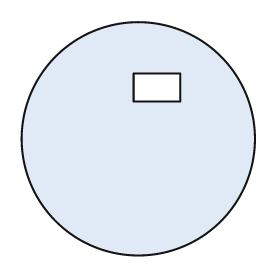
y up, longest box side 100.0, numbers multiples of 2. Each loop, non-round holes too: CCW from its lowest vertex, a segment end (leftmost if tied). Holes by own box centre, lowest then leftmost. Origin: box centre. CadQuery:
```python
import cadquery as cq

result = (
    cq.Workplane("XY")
    .moveTo(0.0, 0.0)
    .circle(50.0)
    .moveTo(-2.0, 16.0)
    .lineTo(18.0, 16.0)
    .lineTo(18.0, 28.0)
    .lineTo(-2.0, 28.0)
    .close()
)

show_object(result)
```